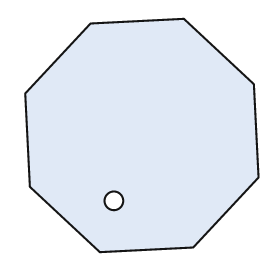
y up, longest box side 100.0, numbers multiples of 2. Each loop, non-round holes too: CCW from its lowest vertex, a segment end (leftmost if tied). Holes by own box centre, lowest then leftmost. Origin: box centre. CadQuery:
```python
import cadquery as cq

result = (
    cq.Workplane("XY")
    .moveTo(-18.0, -50.0)
    .lineTo(22.0, -48.0)
    .lineTo(50.0, -18.0)
    .lineTo(48.0, 22.0)
    .lineTo(18.0, 50.0)
    .lineTo(-22.0, 48.0)
    .lineTo(-50.0, 18.0)
    .lineTo(-48.0, -22.0)
    .close()
    .moveTo(-12.0, -28.0)
    .circle(4.0)
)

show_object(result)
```